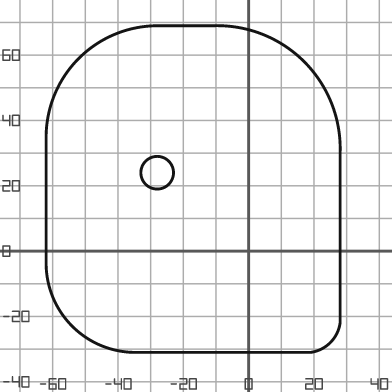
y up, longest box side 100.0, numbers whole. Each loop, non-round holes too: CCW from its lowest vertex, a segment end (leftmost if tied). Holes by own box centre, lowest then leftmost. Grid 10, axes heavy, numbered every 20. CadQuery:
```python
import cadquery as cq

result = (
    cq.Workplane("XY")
    .moveTo(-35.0, -31.0)
    .lineTo(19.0, -31.0)
    .threePointArc((25.0, -28.0), (28.0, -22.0))
    .lineTo(28.0, 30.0)
    .threePointArc((17.0, 58.0), (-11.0, 69.0))
    .lineTo(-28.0, 69.0)
    .threePointArc((-52.0, 59.0), (-62.0, 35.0))
    .lineTo(-62.0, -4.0)
    .threePointArc((-54.0, -23.0), (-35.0, -31.0))
    .close()
    .moveTo(-28.0, 24.0)
    .circle(5.0)
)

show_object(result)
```